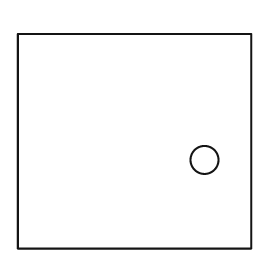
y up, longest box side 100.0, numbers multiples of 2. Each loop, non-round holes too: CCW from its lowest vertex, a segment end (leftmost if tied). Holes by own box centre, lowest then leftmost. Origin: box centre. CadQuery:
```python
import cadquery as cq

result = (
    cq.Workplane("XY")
    .moveTo(-50.0, -46.0)
    .lineTo(50.0, -46.0)
    .lineTo(50.0, 46.0)
    .lineTo(-50.0, 46.0)
    .close()
    .moveTo(30.0, -8.0)
    .circle(6.0)
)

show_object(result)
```